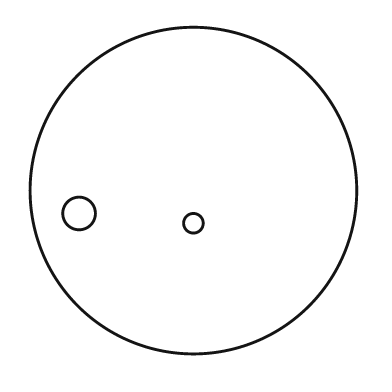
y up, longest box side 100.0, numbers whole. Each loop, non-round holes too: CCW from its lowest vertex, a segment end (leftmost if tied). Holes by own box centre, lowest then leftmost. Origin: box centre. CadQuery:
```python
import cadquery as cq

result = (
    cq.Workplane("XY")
    .moveTo(0.0, 0.0)
    .circle(50.0)
    .moveTo(0.0, -10.0)
    .circle(3.0)
    .moveTo(-35.0, -7.0)
    .circle(5.0)
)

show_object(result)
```